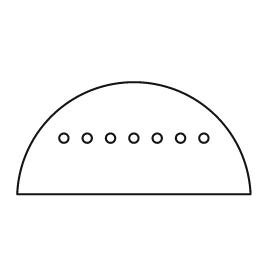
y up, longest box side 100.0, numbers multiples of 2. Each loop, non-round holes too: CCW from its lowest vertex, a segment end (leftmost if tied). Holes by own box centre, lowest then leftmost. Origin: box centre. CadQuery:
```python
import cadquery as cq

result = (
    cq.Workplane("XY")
    .moveTo(-50.0, -24.0)
    .lineTo(50.0, -24.0)
    .threePointArc((0.0, 24.0), (-50.0, -24.0))
    .close()
    .moveTo(-30.0, 0.0)
    .circle(2.0)
    .moveTo(-20.0, 0.0)
    .circle(2.0)
    .moveTo(-10.0, 0.0)
    .circle(2.0)
    .moveTo(0.0, 0.0)
    .circle(2.0)
    .moveTo(10.0, 0.0)
    .circle(2.0)
    .moveTo(20.0, 0.0)
    .circle(2.0)
    .moveTo(30.0, 0.0)
    .circle(2.0)
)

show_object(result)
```